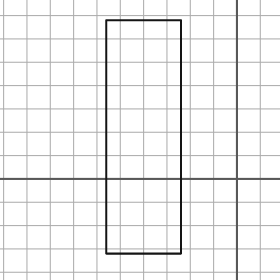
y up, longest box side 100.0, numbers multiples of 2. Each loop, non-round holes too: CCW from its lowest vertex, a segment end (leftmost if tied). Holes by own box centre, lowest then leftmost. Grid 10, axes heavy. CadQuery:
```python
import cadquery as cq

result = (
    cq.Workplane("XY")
    .moveTo(-56.0, -32.0)
    .lineTo(-24.0, -32.0)
    .lineTo(-24.0, 68.0)
    .lineTo(-56.0, 68.0)
    .close()
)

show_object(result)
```